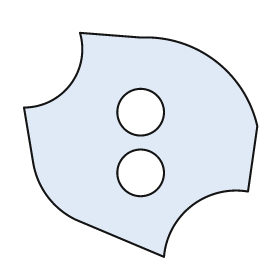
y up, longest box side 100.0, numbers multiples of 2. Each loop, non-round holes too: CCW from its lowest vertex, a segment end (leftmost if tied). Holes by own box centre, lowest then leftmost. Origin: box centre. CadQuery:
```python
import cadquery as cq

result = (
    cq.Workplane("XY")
    .moveTo(10.0, -48.0)
    .threePointArc((22.0, -26.0), (46.0, -20.0))
    .lineTo(50.0, 8.0)
    .threePointArc((32.0, 36.0), (0.0, 46.0))
    .lineTo(-26.0, 48.0)
    .threePointArc((-30.0, 26.0), (-50.0, 16.0))
    .lineTo(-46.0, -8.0)
    .threePointArc((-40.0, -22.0), (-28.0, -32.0))
    .close()
    .moveTo(0.0, -12.0)
    .circle(10.0)
    .moveTo(0.0, 14.0)
    .circle(10.0)
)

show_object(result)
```